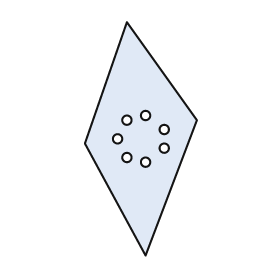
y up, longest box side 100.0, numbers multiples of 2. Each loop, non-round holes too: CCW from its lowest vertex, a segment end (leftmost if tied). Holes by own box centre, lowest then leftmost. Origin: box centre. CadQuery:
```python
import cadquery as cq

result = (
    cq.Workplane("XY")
    .moveTo(2.0, -50.0)
    .lineTo(24.0, 8.0)
    .lineTo(-6.0, 50.0)
    .lineTo(-24.0, -2.0)
    .close()
    .moveTo(2.0, -10.0)
    .circle(2.0)
    .moveTo(-6.0, -8.0)
    .circle(2.0)
    .moveTo(10.0, -4.0)
    .circle(2.0)
    .moveTo(-10.0, 0.0)
    .circle(2.0)
    .moveTo(10.0, 4.0)
    .circle(2.0)
    .moveTo(-6.0, 8.0)
    .circle(2.0)
    .moveTo(2.0, 10.0)
    .circle(2.0)
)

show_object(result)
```